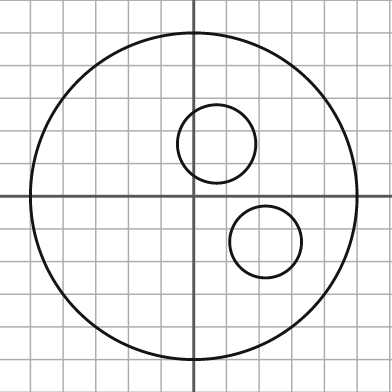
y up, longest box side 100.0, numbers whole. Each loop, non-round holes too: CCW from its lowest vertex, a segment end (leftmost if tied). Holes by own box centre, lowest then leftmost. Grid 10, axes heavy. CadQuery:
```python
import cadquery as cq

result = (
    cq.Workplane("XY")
    .moveTo(0.0, 0.0)
    .circle(50.0)
    .moveTo(22.0, -14.0)
    .circle(11.0)
    .moveTo(7.0, 16.0)
    .circle(12.0)
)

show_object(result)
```